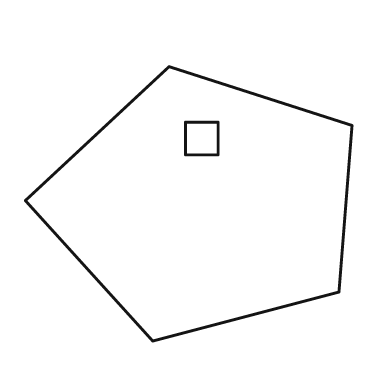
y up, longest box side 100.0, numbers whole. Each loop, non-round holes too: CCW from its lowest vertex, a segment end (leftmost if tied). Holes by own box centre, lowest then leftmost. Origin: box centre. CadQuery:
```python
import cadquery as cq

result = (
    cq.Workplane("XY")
    .moveTo(-11.0, -42.0)
    .lineTo(46.0, -27.0)
    .lineTo(50.0, 24.0)
    .lineTo(-6.0, 42.0)
    .lineTo(-50.0, 1.0)
    .close()
    .moveTo(-1.0, 15.0)
    .lineTo(9.0, 15.0)
    .lineTo(9.0, 25.0)
    .lineTo(-1.0, 25.0)
    .close()
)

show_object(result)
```